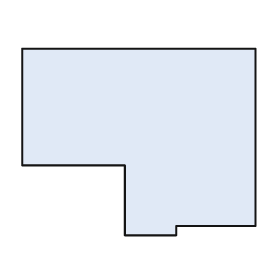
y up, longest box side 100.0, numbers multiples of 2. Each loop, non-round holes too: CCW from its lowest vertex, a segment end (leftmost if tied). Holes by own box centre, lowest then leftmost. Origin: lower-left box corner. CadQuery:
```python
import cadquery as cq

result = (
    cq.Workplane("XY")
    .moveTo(44.0, 0.0)
    .lineTo(66.0, 0.0)
    .lineTo(66.0, 4.0)
    .lineTo(100.0, 4.0)
    .lineTo(100.0, 80.0)
    .lineTo(0.0, 80.0)
    .lineTo(0.0, 30.0)
    .lineTo(44.0, 30.0)
    .close()
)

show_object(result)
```